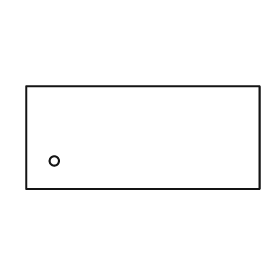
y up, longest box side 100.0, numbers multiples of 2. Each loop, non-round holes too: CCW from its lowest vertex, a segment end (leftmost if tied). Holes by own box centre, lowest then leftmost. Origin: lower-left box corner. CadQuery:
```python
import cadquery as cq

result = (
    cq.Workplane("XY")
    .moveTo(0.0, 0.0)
    .lineTo(100.0, 0.0)
    .lineTo(100.0, 44.0)
    .lineTo(0.0, 44.0)
    .close()
    .moveTo(12.0, 12.0)
    .circle(2.0)
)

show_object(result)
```